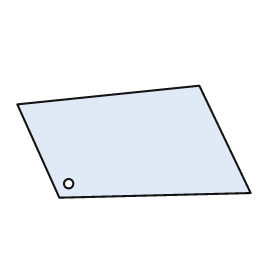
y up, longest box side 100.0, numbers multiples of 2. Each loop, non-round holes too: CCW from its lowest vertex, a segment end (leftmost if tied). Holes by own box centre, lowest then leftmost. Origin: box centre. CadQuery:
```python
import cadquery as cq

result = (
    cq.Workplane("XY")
    .moveTo(-32.0, -24.0)
    .lineTo(50.0, -22.0)
    .lineTo(28.0, 24.0)
    .lineTo(-50.0, 16.0)
    .close()
    .moveTo(-28.0, -18.0)
    .circle(2.0)
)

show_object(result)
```